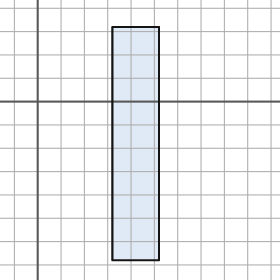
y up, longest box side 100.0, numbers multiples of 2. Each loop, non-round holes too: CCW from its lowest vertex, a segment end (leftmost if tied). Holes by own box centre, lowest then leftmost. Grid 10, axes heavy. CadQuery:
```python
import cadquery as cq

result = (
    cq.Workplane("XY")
    .moveTo(32.0, -68.0)
    .lineTo(52.0, -68.0)
    .lineTo(52.0, 32.0)
    .lineTo(32.0, 32.0)
    .close()
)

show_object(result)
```